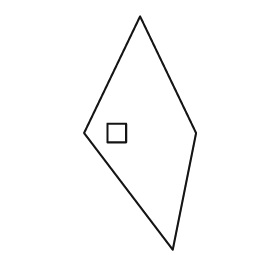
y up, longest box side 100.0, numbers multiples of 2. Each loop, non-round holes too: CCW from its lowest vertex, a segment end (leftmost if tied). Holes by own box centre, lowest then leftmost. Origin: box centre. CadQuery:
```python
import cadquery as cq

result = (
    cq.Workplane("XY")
    .moveTo(14.0, -50.0)
    .lineTo(24.0, 0.0)
    .lineTo(0.0, 50.0)
    .lineTo(-24.0, 0.0)
    .close()
    .moveTo(-14.0, -4.0)
    .lineTo(-6.0, -4.0)
    .lineTo(-6.0, 4.0)
    .lineTo(-14.0, 4.0)
    .close()
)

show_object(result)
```